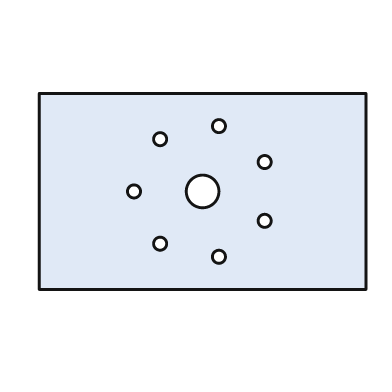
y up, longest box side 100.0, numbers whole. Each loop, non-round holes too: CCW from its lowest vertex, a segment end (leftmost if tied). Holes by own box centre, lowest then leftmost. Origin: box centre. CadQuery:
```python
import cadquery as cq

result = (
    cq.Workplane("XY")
    .moveTo(-50.0, -30.0)
    .lineTo(50.0, -30.0)
    .lineTo(50.0, 30.0)
    .lineTo(-50.0, 30.0)
    .close()
    .moveTo(5.0, -20.0)
    .circle(2.0)
    .moveTo(-13.0, -16.0)
    .circle(2.0)
    .moveTo(19.0, -9.0)
    .circle(2.0)
    .moveTo(-21.0, 0.0)
    .circle(2.0)
    .moveTo(0.0, 0.0)
    .circle(5.0)
    .moveTo(19.0, 9.0)
    .circle(2.0)
    .moveTo(-13.0, 16.0)
    .circle(2.0)
    .moveTo(5.0, 20.0)
    .circle(2.0)
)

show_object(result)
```